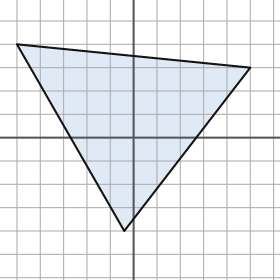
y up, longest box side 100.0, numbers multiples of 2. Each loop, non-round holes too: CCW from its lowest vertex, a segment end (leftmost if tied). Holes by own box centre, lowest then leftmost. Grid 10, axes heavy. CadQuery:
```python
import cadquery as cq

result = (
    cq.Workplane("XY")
    .moveTo(-4.0, -40.0)
    .lineTo(50.0, 30.0)
    .lineTo(-50.0, 40.0)
    .close()
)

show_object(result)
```